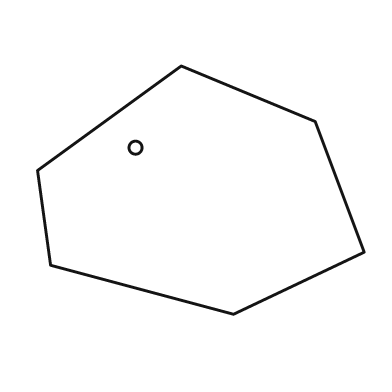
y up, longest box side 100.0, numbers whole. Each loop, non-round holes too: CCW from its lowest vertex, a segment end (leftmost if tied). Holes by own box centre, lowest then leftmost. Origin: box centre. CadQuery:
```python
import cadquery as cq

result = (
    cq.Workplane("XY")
    .moveTo(10.0, -38.0)
    .lineTo(50.0, -19.0)
    .lineTo(35.0, 21.0)
    .lineTo(-6.0, 38.0)
    .lineTo(-50.0, 6.0)
    .lineTo(-46.0, -23.0)
    .close()
    .moveTo(-20.0, 13.0)
    .circle(2.0)
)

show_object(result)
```